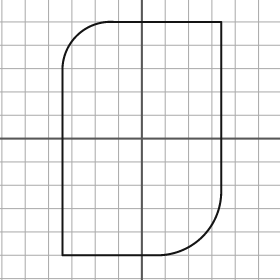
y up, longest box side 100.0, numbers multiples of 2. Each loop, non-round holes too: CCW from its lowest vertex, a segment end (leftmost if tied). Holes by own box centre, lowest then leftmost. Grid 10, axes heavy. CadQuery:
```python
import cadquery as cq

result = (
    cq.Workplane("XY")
    .moveTo(-34.0, -50.0)
    .lineTo(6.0, -50.0)
    .threePointArc((26.0, -42.0), (34.0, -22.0))
    .lineTo(34.0, 50.0)
    .lineTo(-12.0, 50.0)
    .threePointArc((-28.0, 44.0), (-34.0, 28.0))
    .close()
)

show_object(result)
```